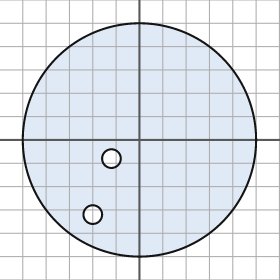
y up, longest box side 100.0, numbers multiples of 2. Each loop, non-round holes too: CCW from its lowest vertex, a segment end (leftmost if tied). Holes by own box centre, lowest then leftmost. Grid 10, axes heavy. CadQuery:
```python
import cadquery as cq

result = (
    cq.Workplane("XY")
    .moveTo(0.0, 0.0)
    .circle(50.0)
    .moveTo(-20.0, -32.0)
    .circle(4.0)
    .moveTo(-12.0, -8.0)
    .circle(4.0)
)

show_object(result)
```